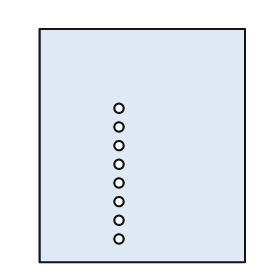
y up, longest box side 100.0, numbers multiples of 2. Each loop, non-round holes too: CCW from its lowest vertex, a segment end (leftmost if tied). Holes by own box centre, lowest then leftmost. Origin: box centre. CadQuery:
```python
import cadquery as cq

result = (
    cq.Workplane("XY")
    .moveTo(-44.0, -50.0)
    .lineTo(44.0, -50.0)
    .lineTo(44.0, 50.0)
    .lineTo(-44.0, 50.0)
    .close()
    .moveTo(-10.0, -40.0)
    .circle(2.0)
    .moveTo(-10.0, -32.0)
    .circle(2.0)
    .moveTo(-10.0, -24.0)
    .circle(2.0)
    .moveTo(-10.0, -16.0)
    .circle(2.0)
    .moveTo(-10.0, -8.0)
    .circle(2.0)
    .moveTo(-10.0, 0.0)
    .circle(2.0)
    .moveTo(-10.0, 8.0)
    .circle(2.0)
    .moveTo(-10.0, 16.0)
    .circle(2.0)
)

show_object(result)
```